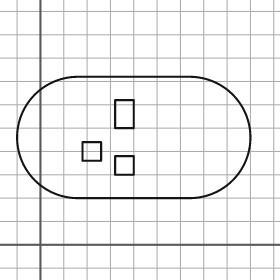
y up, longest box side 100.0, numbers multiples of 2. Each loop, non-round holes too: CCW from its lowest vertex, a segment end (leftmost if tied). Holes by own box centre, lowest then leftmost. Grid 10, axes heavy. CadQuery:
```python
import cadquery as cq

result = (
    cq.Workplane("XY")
    .moveTo(16.0, 20.0)
    .lineTo(64.0, 20.0)
    .threePointArc((90.0, 46.0), (64.0, 72.0))
    .lineTo(16.0, 72.0)
    .threePointArc((-10.0, 46.0), (16.0, 20.0))
    .close()
    .moveTo(32.0, 30.0)
    .lineTo(40.0, 30.0)
    .lineTo(40.0, 38.0)
    .lineTo(32.0, 38.0)
    .close()
    .moveTo(18.0, 36.0)
    .lineTo(26.0, 36.0)
    .lineTo(26.0, 44.0)
    .lineTo(18.0, 44.0)
    .close()
    .moveTo(32.0, 50.0)
    .lineTo(40.0, 50.0)
    .lineTo(40.0, 62.0)
    .lineTo(32.0, 62.0)
    .close()
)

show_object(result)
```